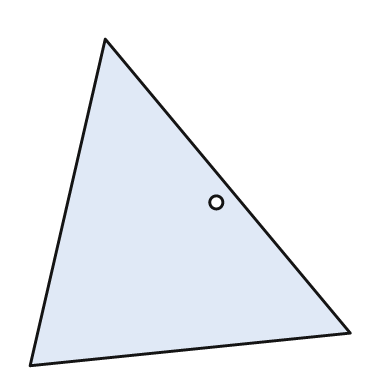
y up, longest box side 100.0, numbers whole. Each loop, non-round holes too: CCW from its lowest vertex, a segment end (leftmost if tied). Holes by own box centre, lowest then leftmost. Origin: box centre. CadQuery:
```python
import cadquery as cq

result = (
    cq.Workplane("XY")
    .moveTo(-49.0, -50.0)
    .lineTo(49.0, -40.0)
    .lineTo(-26.0, 50.0)
    .close()
    .moveTo(8.0, 0.0)
    .circle(2.0)
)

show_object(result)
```